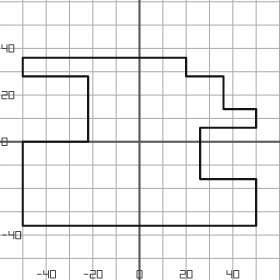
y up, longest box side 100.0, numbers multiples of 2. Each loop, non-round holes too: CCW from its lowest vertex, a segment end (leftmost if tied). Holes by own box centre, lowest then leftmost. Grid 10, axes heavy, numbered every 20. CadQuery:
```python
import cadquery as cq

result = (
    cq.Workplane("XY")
    .moveTo(-50.0, -36.0)
    .lineTo(50.0, -36.0)
    .lineTo(50.0, -16.0)
    .lineTo(26.0, -16.0)
    .lineTo(26.0, 6.0)
    .lineTo(50.0, 6.0)
    .lineTo(50.0, 14.0)
    .lineTo(36.0, 14.0)
    .lineTo(36.0, 28.0)
    .lineTo(20.0, 28.0)
    .lineTo(20.0, 36.0)
    .lineTo(-50.0, 36.0)
    .lineTo(-50.0, 28.0)
    .lineTo(-22.0, 28.0)
    .lineTo(-22.0, 0.0)
    .lineTo(-50.0, 0.0)
    .close()
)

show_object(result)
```